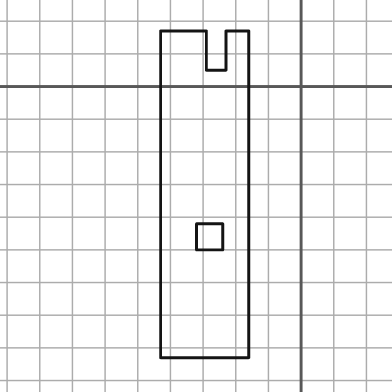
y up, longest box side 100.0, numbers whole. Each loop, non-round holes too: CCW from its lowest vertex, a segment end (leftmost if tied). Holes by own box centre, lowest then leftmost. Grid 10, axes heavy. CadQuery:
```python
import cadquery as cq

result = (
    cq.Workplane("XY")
    .moveTo(-43.0, -83.0)
    .lineTo(-16.0, -83.0)
    .lineTo(-16.0, 17.0)
    .lineTo(-23.0, 17.0)
    .lineTo(-23.0, 5.0)
    .lineTo(-29.0, 5.0)
    .lineTo(-29.0, 17.0)
    .lineTo(-43.0, 17.0)
    .close()
    .moveTo(-32.0, -50.0)
    .lineTo(-24.0, -50.0)
    .lineTo(-24.0, -42.0)
    .lineTo(-32.0, -42.0)
    .close()
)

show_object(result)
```